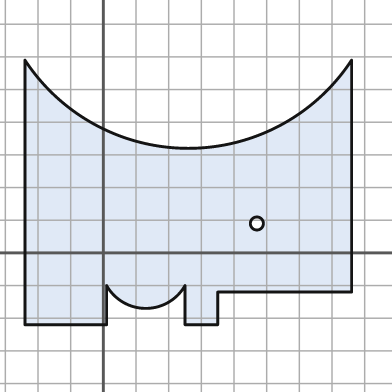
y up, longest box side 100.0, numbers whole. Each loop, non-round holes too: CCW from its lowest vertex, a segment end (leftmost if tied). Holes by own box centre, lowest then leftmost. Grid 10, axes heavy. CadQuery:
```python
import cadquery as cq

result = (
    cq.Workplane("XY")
    .moveTo(-24.0, -22.0)
    .lineTo(1.0, -22.0)
    .lineTo(1.0, -10.0)
    .threePointArc((13.0, -17.0), (25.0, -10.0))
    .lineTo(25.0, -22.0)
    .lineTo(35.0, -22.0)
    .lineTo(35.0, -12.0)
    .lineTo(76.0, -12.0)
    .lineTo(76.0, 59.0)
    .threePointArc((26.0, 32.0), (-24.0, 59.0))
    .close()
    .moveTo(47.0, 9.0)
    .circle(2.0)
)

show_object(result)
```